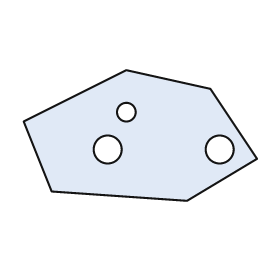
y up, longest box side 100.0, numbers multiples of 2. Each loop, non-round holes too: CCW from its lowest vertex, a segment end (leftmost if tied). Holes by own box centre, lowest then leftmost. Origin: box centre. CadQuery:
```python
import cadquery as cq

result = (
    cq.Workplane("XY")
    .moveTo(20.0, -28.0)
    .lineTo(50.0, -10.0)
    .lineTo(30.0, 20.0)
    .lineTo(-6.0, 28.0)
    .lineTo(-50.0, 6.0)
    .lineTo(-38.0, -24.0)
    .close()
    .moveTo(-14.0, -6.0)
    .circle(6.0)
    .moveTo(34.0, -6.0)
    .circle(6.0)
    .moveTo(-6.0, 10.0)
    .circle(4.0)
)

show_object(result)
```